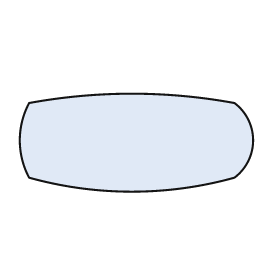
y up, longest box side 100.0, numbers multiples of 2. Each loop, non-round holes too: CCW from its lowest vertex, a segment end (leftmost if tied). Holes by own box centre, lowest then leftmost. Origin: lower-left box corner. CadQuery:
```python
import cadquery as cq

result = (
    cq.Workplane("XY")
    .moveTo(4.0, 6.0)
    .threePointArc((48.0, 0.0), (92.0, 6.0))
    .threePointArc((100.0, 22.0), (92.0, 38.0))
    .threePointArc((48.0, 42.0), (4.0, 38.0))
    .threePointArc((0.0, 22.0), (4.0, 6.0))
    .close()
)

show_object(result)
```